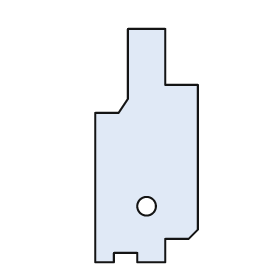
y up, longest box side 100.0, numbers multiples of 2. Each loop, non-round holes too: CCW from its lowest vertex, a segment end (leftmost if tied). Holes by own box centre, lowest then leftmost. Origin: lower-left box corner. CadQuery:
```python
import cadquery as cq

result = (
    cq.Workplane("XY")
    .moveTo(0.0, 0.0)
    .lineTo(8.0, 0.0)
    .lineTo(8.0, 4.0)
    .lineTo(18.0, 4.0)
    .lineTo(18.0, 0.0)
    .lineTo(30.0, 0.0)
    .lineTo(30.0, 10.0)
    .lineTo(40.0, 10.0)
    .lineTo(44.0, 14.0)
    .lineTo(44.0, 76.0)
    .lineTo(30.0, 76.0)
    .lineTo(30.0, 100.0)
    .lineTo(14.0, 100.0)
    .lineTo(14.0, 70.0)
    .lineTo(10.0, 64.0)
    .lineTo(0.0, 64.0)
    .close()
    .moveTo(22.0, 24.0)
    .circle(4.0)
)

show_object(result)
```